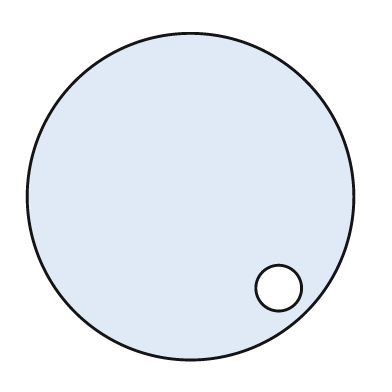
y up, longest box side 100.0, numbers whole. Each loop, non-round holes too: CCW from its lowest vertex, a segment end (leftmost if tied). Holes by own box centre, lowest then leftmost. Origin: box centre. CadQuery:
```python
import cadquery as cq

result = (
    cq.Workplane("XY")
    .moveTo(0.0, 0.0)
    .circle(50.0)
    .moveTo(27.0, -28.0)
    .circle(7.0)
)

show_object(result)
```